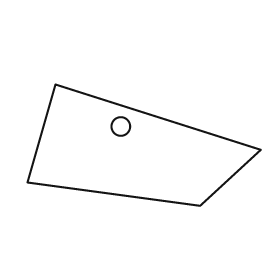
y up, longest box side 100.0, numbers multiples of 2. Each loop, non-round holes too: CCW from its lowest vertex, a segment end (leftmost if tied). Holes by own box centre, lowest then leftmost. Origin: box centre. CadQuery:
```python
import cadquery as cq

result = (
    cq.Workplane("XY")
    .moveTo(24.0, -26.0)
    .lineTo(50.0, -2.0)
    .lineTo(-38.0, 26.0)
    .lineTo(-50.0, -16.0)
    .close()
    .moveTo(-10.0, 8.0)
    .circle(4.0)
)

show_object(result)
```